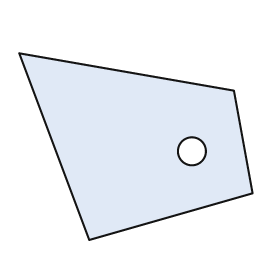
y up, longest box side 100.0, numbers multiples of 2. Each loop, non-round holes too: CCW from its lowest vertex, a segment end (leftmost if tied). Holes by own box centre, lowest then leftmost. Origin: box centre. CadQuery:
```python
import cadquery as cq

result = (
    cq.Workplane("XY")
    .moveTo(-20.0, -40.0)
    .lineTo(50.0, -20.0)
    .lineTo(42.0, 24.0)
    .lineTo(-50.0, 40.0)
    .close()
    .moveTo(24.0, -2.0)
    .circle(6.0)
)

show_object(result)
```